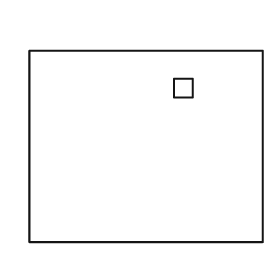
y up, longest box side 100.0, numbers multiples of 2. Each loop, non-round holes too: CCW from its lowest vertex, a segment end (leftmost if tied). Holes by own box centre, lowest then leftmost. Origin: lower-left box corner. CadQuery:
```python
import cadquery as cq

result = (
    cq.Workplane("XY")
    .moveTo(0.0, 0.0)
    .lineTo(100.0, 0.0)
    .lineTo(100.0, 82.0)
    .lineTo(0.0, 82.0)
    .close()
    .moveTo(62.0, 62.0)
    .lineTo(70.0, 62.0)
    .lineTo(70.0, 70.0)
    .lineTo(62.0, 70.0)
    .close()
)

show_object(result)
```